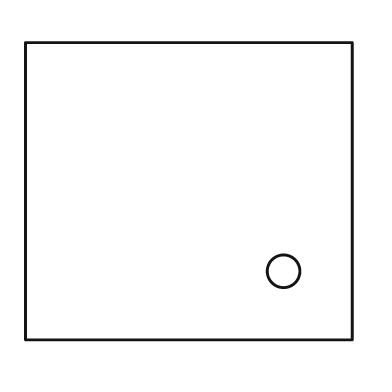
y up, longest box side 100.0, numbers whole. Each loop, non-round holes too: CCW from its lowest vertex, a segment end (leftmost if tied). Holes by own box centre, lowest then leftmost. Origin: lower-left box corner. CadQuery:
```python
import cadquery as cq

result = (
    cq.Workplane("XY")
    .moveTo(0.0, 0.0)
    .lineTo(100.0, 0.0)
    .lineTo(100.0, 91.0)
    .lineTo(0.0, 91.0)
    .close()
    .moveTo(79.0, 21.0)
    .circle(5.0)
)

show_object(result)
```